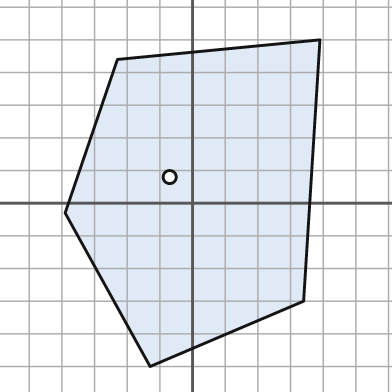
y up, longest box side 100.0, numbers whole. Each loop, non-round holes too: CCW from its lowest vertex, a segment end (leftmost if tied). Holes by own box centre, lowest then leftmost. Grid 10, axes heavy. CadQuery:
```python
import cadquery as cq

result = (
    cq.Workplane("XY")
    .moveTo(-13.0, -50.0)
    .lineTo(34.0, -30.0)
    .lineTo(39.0, 50.0)
    .lineTo(-23.0, 44.0)
    .lineTo(-39.0, -3.0)
    .close()
    .moveTo(-7.0, 8.0)
    .circle(2.0)
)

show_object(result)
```